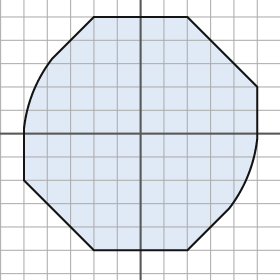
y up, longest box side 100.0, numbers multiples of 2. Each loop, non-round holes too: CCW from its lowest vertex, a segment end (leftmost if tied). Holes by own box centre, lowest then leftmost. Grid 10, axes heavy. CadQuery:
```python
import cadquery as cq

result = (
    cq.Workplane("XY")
    .moveTo(-20.0, -50.0)
    .lineTo(20.0, -50.0)
    .lineTo(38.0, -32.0)
    .threePointArc((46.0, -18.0), (50.0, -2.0))
    .lineTo(50.0, 20.0)
    .lineTo(20.0, 50.0)
    .lineTo(-20.0, 50.0)
    .lineTo(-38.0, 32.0)
    .threePointArc((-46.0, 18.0), (-50.0, 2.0))
    .lineTo(-50.0, -20.0)
    .close()
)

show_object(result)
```